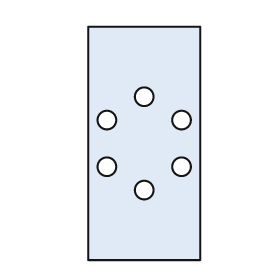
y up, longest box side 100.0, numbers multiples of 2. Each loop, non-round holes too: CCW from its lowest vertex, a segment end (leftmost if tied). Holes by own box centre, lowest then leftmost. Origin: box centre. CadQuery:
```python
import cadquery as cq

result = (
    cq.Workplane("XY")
    .moveTo(-24.0, -50.0)
    .lineTo(24.0, -50.0)
    .lineTo(24.0, 50.0)
    .lineTo(-24.0, 50.0)
    .close()
    .moveTo(0.0, -20.0)
    .circle(4.0)
    .moveTo(-16.0, -10.0)
    .circle(4.0)
    .moveTo(16.0, -10.0)
    .circle(4.0)
    .moveTo(-16.0, 10.0)
    .circle(4.0)
    .moveTo(16.0, 10.0)
    .circle(4.0)
    .moveTo(0.0, 20.0)
    .circle(4.0)
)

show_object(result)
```